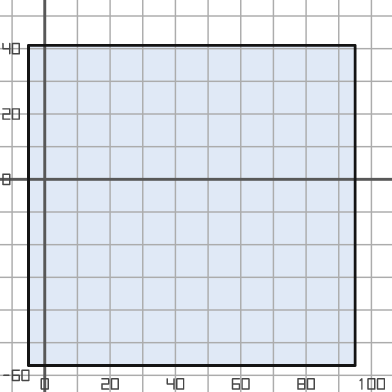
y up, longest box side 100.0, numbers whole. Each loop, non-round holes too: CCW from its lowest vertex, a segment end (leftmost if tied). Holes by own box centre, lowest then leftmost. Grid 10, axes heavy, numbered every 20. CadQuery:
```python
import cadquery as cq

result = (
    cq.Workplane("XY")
    .moveTo(-5.0, -57.0)
    .lineTo(95.0, -57.0)
    .lineTo(95.0, 41.0)
    .lineTo(-5.0, 41.0)
    .close()
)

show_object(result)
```